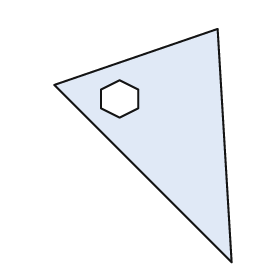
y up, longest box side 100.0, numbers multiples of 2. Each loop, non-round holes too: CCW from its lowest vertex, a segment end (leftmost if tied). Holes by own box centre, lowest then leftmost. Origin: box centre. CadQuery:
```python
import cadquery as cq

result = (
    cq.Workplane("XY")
    .moveTo(38.0, -50.0)
    .lineTo(32.0, 50.0)
    .lineTo(-38.0, 26.0)
    .close()
    .moveTo(-10.0, 12.0)
    .lineTo(-2.0, 16.0)
    .lineTo(-2.0, 24.0)
    .lineTo(-10.0, 28.0)
    .lineTo(-18.0, 24.0)
    .lineTo(-18.0, 16.0)
    .close()
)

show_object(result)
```